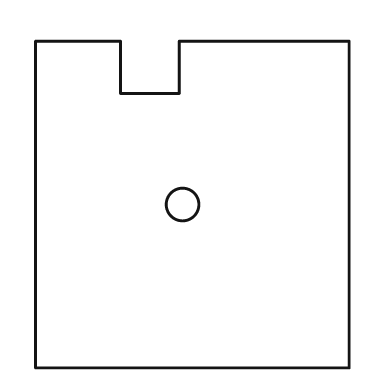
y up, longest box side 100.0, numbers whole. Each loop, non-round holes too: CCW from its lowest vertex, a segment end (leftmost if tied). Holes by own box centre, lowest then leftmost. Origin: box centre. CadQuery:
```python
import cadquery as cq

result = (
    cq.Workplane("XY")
    .moveTo(-48.0, -50.0)
    .lineTo(48.0, -50.0)
    .lineTo(48.0, 50.0)
    .lineTo(-4.0, 50.0)
    .lineTo(-4.0, 34.0)
    .lineTo(-22.0, 34.0)
    .lineTo(-22.0, 50.0)
    .lineTo(-48.0, 50.0)
    .close()
    .moveTo(-3.0, 0.0)
    .circle(5.0)
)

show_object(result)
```